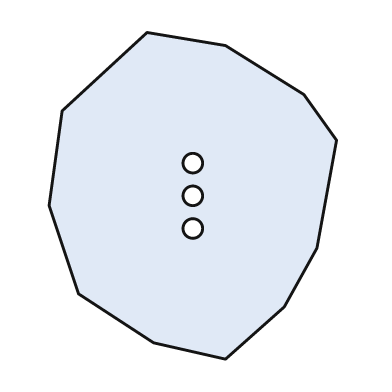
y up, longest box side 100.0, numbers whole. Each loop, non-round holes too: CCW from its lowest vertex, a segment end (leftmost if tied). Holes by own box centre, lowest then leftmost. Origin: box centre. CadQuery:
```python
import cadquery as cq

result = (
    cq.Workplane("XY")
    .moveTo(10.0, -50.0)
    .lineTo(28.0, -34.0)
    .lineTo(38.0, -16.0)
    .lineTo(44.0, 17.0)
    .lineTo(34.0, 31.0)
    .lineTo(10.0, 46.0)
    .lineTo(-14.0, 50.0)
    .lineTo(-40.0, 26.0)
    .lineTo(-44.0, -3.0)
    .lineTo(-35.0, -30.0)
    .lineTo(-12.0, -45.0)
    .close()
    .moveTo(0.0, -10.0)
    .circle(3.0)
    .moveTo(0.0, 0.0)
    .circle(3.0)
    .moveTo(0.0, 10.0)
    .circle(3.0)
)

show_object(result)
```